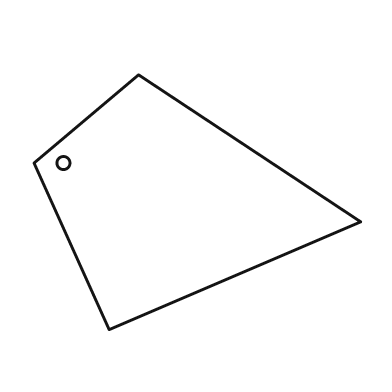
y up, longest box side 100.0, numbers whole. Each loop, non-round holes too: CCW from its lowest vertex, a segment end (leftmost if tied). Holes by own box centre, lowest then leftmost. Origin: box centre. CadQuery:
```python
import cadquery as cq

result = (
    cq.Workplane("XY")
    .moveTo(-27.0, -39.0)
    .lineTo(50.0, -6.0)
    .lineTo(-18.0, 39.0)
    .lineTo(-50.0, 12.0)
    .close()
    .moveTo(-41.0, 12.0)
    .circle(2.0)
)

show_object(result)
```